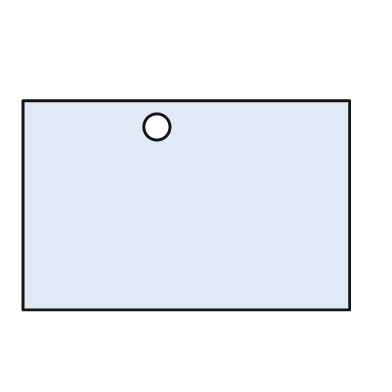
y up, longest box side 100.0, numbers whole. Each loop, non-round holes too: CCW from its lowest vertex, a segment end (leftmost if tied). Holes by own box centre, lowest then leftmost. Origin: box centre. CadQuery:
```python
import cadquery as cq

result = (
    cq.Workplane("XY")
    .moveTo(-50.0, -32.0)
    .lineTo(50.0, -32.0)
    .lineTo(50.0, 32.0)
    .lineTo(-50.0, 32.0)
    .close()
    .moveTo(-9.0, 24.0)
    .circle(4.0)
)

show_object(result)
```